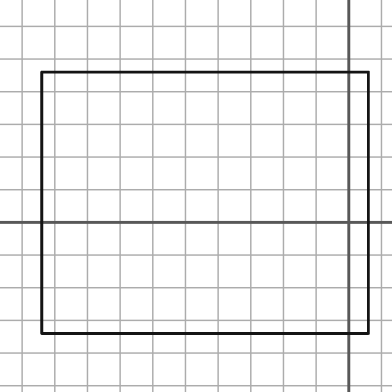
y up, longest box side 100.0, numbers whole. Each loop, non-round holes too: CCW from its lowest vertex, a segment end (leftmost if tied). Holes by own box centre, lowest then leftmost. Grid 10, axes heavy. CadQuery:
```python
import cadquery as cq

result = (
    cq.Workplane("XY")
    .moveTo(-94.0, -34.0)
    .lineTo(6.0, -34.0)
    .lineTo(6.0, 46.0)
    .lineTo(-94.0, 46.0)
    .close()
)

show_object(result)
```